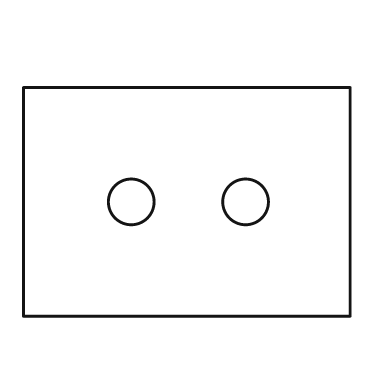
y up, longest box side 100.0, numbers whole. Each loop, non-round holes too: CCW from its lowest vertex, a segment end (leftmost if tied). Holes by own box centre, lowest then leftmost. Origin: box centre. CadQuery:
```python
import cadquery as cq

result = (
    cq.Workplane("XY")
    .moveTo(-50.0, -35.0)
    .lineTo(50.0, -35.0)
    .lineTo(50.0, 35.0)
    .lineTo(-50.0, 35.0)
    .close()
    .moveTo(-17.0, 0.0)
    .circle(7.0)
    .moveTo(18.0, 0.0)
    .circle(7.0)
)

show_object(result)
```